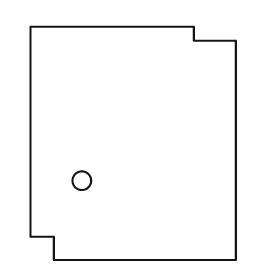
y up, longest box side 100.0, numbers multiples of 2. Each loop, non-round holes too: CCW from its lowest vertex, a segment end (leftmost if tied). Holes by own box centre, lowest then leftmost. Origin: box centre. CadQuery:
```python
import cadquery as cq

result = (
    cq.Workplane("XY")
    .moveTo(-34.0, -50.0)
    .lineTo(44.0, -50.0)
    .lineTo(44.0, 44.0)
    .lineTo(26.0, 44.0)
    .lineTo(26.0, 50.0)
    .lineTo(-44.0, 50.0)
    .lineTo(-44.0, -40.0)
    .lineTo(-34.0, -40.0)
    .close()
    .moveTo(-22.0, -16.0)
    .circle(4.0)
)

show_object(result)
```